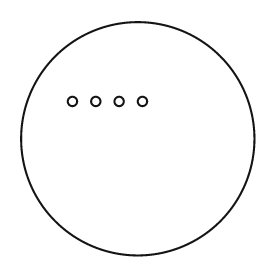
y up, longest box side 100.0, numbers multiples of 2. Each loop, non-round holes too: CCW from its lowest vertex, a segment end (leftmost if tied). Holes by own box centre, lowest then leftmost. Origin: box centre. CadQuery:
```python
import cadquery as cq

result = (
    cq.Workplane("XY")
    .moveTo(0.0, 0.0)
    .circle(50.0)
    .moveTo(-28.0, 16.0)
    .circle(2.0)
    .moveTo(-18.0, 16.0)
    .circle(2.0)
    .moveTo(-8.0, 16.0)
    .circle(2.0)
    .moveTo(2.0, 16.0)
    .circle(2.0)
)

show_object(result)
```